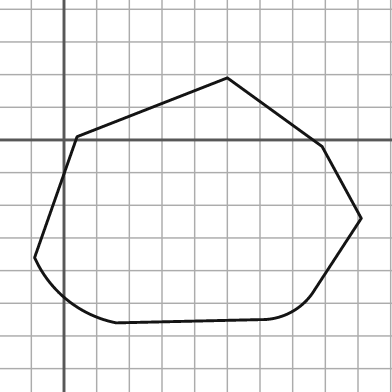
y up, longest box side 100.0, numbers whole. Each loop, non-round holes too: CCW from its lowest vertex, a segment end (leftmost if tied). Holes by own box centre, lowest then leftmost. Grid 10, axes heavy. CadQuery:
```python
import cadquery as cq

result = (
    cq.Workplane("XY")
    .moveTo(16.0, -56.0)
    .lineTo(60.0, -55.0)
    .threePointArc((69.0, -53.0), (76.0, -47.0))
    .lineTo(91.0, -24.0)
    .lineTo(79.0, -2.0)
    .lineTo(50.0, 19.0)
    .lineTo(4.0, 1.0)
    .lineTo(-9.0, -36.0)
    .threePointArc((1.0, -49.0), (16.0, -56.0))
    .close()
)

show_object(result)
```